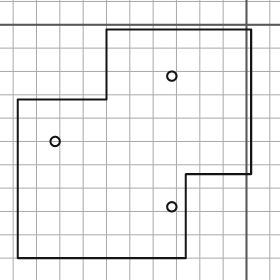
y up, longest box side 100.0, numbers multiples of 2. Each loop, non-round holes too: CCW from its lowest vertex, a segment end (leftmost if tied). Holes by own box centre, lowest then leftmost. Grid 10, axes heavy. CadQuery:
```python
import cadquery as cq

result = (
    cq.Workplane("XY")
    .moveTo(-98.0, -100.0)
    .lineTo(-26.0, -100.0)
    .lineTo(-26.0, -64.0)
    .lineTo(2.0, -64.0)
    .lineTo(2.0, -2.0)
    .lineTo(-60.0, -2.0)
    .lineTo(-60.0, -32.0)
    .lineTo(-98.0, -32.0)
    .close()
    .moveTo(-32.0, -78.0)
    .circle(2.0)
    .moveTo(-82.0, -50.0)
    .circle(2.0)
    .moveTo(-32.0, -22.0)
    .circle(2.0)
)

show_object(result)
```